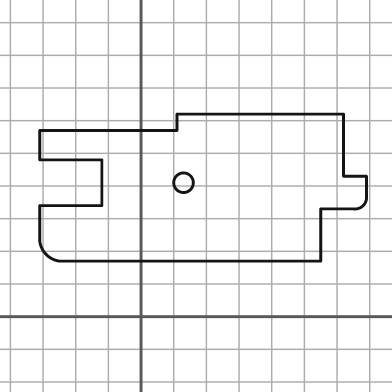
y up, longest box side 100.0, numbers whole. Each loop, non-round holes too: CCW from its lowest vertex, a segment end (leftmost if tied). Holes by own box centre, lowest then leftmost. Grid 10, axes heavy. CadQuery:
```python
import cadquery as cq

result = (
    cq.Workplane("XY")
    .moveTo(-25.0, 17.0)
    .lineTo(55.0, 17.0)
    .lineTo(55.0, 33.0)
    .lineTo(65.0, 33.0)
    .threePointArc((68.0, 34.0), (69.0, 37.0))
    .lineTo(69.0, 43.0)
    .lineTo(62.0, 43.0)
    .lineTo(62.0, 62.0)
    .lineTo(11.0, 62.0)
    .lineTo(11.0, 57.0)
    .lineTo(-31.0, 57.0)
    .lineTo(-31.0, 48.0)
    .lineTo(-12.0, 48.0)
    .lineTo(-12.0, 34.0)
    .lineTo(-31.0, 34.0)
    .lineTo(-31.0, 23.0)
    .threePointArc((-29.0, 19.0), (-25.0, 17.0))
    .close()
    .moveTo(13.0, 41.0)
    .circle(3.0)
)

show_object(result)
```